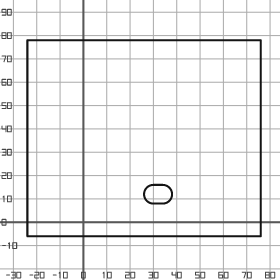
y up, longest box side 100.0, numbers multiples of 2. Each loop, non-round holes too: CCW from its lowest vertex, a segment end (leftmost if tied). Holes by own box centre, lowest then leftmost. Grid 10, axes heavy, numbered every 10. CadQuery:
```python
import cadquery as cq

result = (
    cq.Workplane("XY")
    .moveTo(-24.0, -6.0)
    .lineTo(76.0, -6.0)
    .lineTo(76.0, 78.0)
    .lineTo(-24.0, 78.0)
    .close()
    .moveTo(30.0, 8.0)
    .lineTo(34.0, 8.0)
    .threePointArc((38.0, 12.0), (34.0, 16.0))
    .lineTo(30.0, 16.0)
    .threePointArc((26.0, 12.0), (30.0, 8.0))
    .close()
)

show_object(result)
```